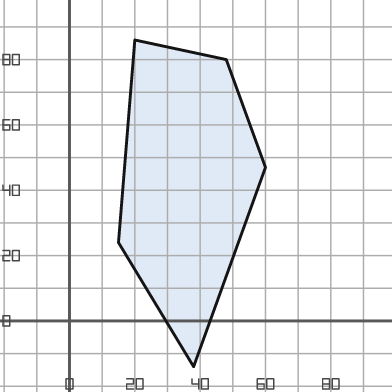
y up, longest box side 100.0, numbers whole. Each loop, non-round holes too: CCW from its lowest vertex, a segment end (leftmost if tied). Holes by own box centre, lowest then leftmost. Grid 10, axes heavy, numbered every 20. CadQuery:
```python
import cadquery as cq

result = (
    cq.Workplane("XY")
    .moveTo(38.0, -14.0)
    .lineTo(60.0, 47.0)
    .lineTo(48.0, 80.0)
    .lineTo(20.0, 86.0)
    .lineTo(15.0, 24.0)
    .close()
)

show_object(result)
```